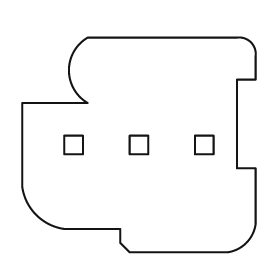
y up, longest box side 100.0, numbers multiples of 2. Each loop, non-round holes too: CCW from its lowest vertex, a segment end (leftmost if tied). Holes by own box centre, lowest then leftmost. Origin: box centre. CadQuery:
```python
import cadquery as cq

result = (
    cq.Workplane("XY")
    .moveTo(-4.0, -46.0)
    .lineTo(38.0, -46.0)
    .threePointArc((46.0, -42.0), (50.0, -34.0))
    .lineTo(50.0, -10.0)
    .lineTo(42.0, -10.0)
    .lineTo(42.0, 28.0)
    .lineTo(50.0, 28.0)
    .lineTo(50.0, 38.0)
    .threePointArc((48.0, 44.0), (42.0, 46.0))
    .lineTo(-22.0, 46.0)
    .threePointArc((-30.0, 32.0), (-22.0, 18.0))
    .lineTo(-50.0, 18.0)
    .lineTo(-50.0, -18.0)
    .threePointArc((-44.0, -30.0), (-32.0, -36.0))
    .lineTo(-8.0, -36.0)
    .lineTo(-8.0, -42.0)
    .close()
    .moveTo(-32.0, -4.0)
    .lineTo(-24.0, -4.0)
    .lineTo(-24.0, 4.0)
    .lineTo(-32.0, 4.0)
    .close()
    .moveTo(-4.0, -4.0)
    .lineTo(4.0, -4.0)
    .lineTo(4.0, 4.0)
    .lineTo(-4.0, 4.0)
    .close()
    .moveTo(24.0, -4.0)
    .lineTo(32.0, -4.0)
    .lineTo(32.0, 4.0)
    .lineTo(24.0, 4.0)
    .close()
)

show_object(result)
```